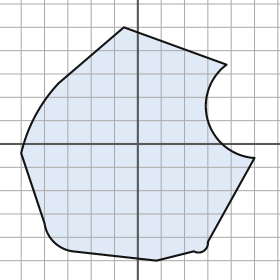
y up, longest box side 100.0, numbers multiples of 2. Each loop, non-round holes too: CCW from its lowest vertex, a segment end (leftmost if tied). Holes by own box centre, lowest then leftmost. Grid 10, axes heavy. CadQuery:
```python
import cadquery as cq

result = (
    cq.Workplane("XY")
    .moveTo(8.0, -50.0)
    .lineTo(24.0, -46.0)
    .threePointArc((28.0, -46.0), (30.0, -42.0))
    .lineTo(50.0, -6.0)
    .threePointArc((30.0, 10.0), (38.0, 34.0))
    .lineTo(-6.0, 50.0)
    .lineTo(-34.0, 26.0)
    .threePointArc((-44.0, 12.0), (-50.0, -4.0))
    .lineTo(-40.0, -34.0)
    .threePointArc((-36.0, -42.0), (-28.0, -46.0))
    .close()
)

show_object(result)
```